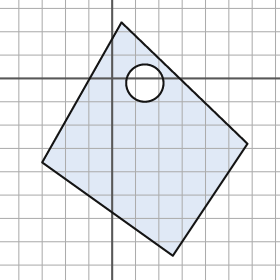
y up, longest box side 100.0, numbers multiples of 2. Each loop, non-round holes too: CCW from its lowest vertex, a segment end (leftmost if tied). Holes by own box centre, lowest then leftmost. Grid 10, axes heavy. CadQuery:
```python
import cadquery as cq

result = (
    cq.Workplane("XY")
    .moveTo(26.0, -76.0)
    .lineTo(58.0, -28.0)
    .lineTo(4.0, 24.0)
    .lineTo(-30.0, -36.0)
    .close()
    .moveTo(14.0, -2.0)
    .circle(8.0)
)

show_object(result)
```